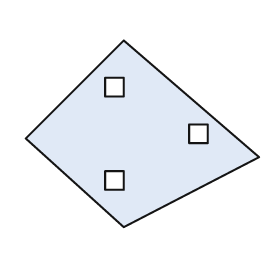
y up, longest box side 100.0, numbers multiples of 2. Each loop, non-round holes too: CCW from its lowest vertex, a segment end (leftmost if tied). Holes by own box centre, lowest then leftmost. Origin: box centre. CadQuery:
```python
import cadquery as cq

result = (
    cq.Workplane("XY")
    .moveTo(-8.0, -40.0)
    .lineTo(50.0, -10.0)
    .lineTo(-8.0, 40.0)
    .lineTo(-50.0, -2.0)
    .close()
    .moveTo(-16.0, -24.0)
    .lineTo(-8.0, -24.0)
    .lineTo(-8.0, -16.0)
    .lineTo(-16.0, -16.0)
    .close()
    .moveTo(20.0, -4.0)
    .lineTo(28.0, -4.0)
    .lineTo(28.0, 4.0)
    .lineTo(20.0, 4.0)
    .close()
    .moveTo(-16.0, 16.0)
    .lineTo(-8.0, 16.0)
    .lineTo(-8.0, 24.0)
    .lineTo(-16.0, 24.0)
    .close()
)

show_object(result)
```